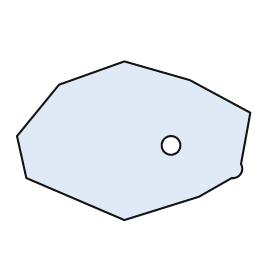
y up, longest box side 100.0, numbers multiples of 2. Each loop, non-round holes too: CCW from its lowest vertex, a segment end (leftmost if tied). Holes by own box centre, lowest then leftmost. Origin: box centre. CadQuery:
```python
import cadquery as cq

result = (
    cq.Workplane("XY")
    .moveTo(-4.0, -34.0)
    .lineTo(28.0, -24.0)
    .lineTo(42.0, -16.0)
    .threePointArc((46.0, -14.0), (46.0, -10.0))
    .lineTo(50.0, 12.0)
    .lineTo(24.0, 26.0)
    .lineTo(-4.0, 34.0)
    .lineTo(-32.0, 24.0)
    .lineTo(-50.0, 2.0)
    .lineTo(-46.0, -16.0)
    .close()
    .moveTo(16.0, -2.0)
    .circle(4.0)
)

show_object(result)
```